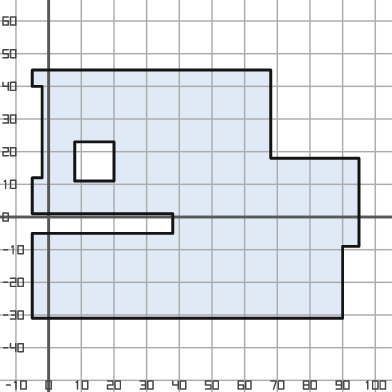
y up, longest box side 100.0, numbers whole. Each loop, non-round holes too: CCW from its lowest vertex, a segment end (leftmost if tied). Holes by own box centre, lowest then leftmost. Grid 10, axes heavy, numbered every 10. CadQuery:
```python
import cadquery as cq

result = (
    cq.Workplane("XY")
    .moveTo(-5.0, -31.0)
    .lineTo(90.0, -31.0)
    .lineTo(90.0, -9.0)
    .lineTo(95.0, -9.0)
    .lineTo(95.0, 18.0)
    .lineTo(68.0, 18.0)
    .lineTo(68.0, 45.0)
    .lineTo(-5.0, 45.0)
    .lineTo(-5.0, 40.0)
    .lineTo(-2.0, 40.0)
    .lineTo(-2.0, 12.0)
    .lineTo(-5.0, 12.0)
    .lineTo(-5.0, 1.0)
    .lineTo(38.0, 1.0)
    .lineTo(38.0, -5.0)
    .lineTo(-5.0, -5.0)
    .close()
    .moveTo(8.0, 11.0)
    .lineTo(20.0, 11.0)
    .lineTo(20.0, 23.0)
    .lineTo(8.0, 23.0)
    .close()
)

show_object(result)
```